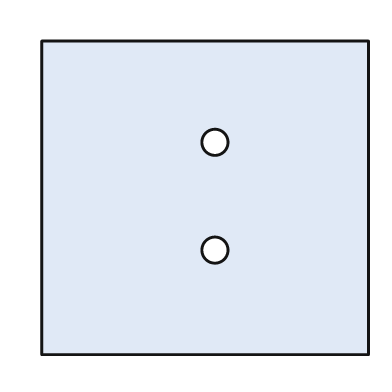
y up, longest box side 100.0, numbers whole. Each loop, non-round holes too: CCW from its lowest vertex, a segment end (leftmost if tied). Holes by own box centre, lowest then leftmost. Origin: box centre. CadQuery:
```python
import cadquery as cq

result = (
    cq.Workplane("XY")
    .moveTo(-50.0, -48.0)
    .lineTo(50.0, -48.0)
    .lineTo(50.0, 48.0)
    .lineTo(-50.0, 48.0)
    .close()
    .moveTo(3.0, -16.0)
    .circle(4.0)
    .moveTo(3.0, 17.0)
    .circle(4.0)
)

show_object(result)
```